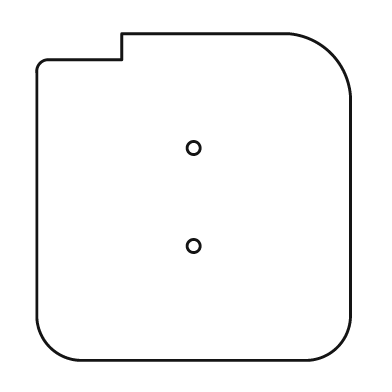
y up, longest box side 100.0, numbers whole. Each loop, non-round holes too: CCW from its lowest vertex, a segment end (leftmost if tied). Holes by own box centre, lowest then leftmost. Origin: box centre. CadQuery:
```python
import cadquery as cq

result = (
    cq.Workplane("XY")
    .moveTo(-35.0, -50.0)
    .lineTo(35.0, -50.0)
    .threePointArc((44.0, -46.0), (48.0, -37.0))
    .lineTo(48.0, 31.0)
    .threePointArc((42.0, 44.0), (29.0, 50.0))
    .lineTo(-22.0, 50.0)
    .lineTo(-22.0, 42.0)
    .lineTo(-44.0, 42.0)
    .threePointArc((-47.0, 41.0), (-48.0, 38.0))
    .lineTo(-48.0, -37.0)
    .threePointArc((-44.0, -46.0), (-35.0, -50.0))
    .close()
    .moveTo(0.0, -15.0)
    .circle(2.0)
    .moveTo(0.0, 15.0)
    .circle(2.0)
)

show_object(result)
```